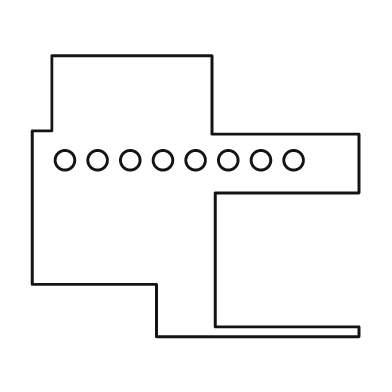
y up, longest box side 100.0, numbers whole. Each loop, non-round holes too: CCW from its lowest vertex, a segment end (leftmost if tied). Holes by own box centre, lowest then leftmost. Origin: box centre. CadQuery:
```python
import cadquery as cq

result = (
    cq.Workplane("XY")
    .moveTo(-12.0, -43.0)
    .lineTo(50.0, -43.0)
    .lineTo(50.0, -40.0)
    .lineTo(6.0, -40.0)
    .lineTo(6.0, 1.0)
    .lineTo(50.0, 1.0)
    .lineTo(50.0, 19.0)
    .lineTo(5.0, 19.0)
    .lineTo(5.0, 43.0)
    .lineTo(-44.0, 43.0)
    .lineTo(-44.0, 20.0)
    .lineTo(-50.0, 20.0)
    .lineTo(-50.0, -27.0)
    .lineTo(-12.0, -27.0)
    .close()
    .moveTo(-40.0, 11.0)
    .circle(3.0)
    .moveTo(-30.0, 11.0)
    .circle(3.0)
    .moveTo(-20.0, 11.0)
    .circle(3.0)
    .moveTo(-10.0, 11.0)
    .circle(3.0)
    .moveTo(0.0, 11.0)
    .circle(3.0)
    .moveTo(10.0, 11.0)
    .circle(3.0)
    .moveTo(20.0, 11.0)
    .circle(3.0)
    .moveTo(30.0, 11.0)
    .circle(3.0)
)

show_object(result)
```